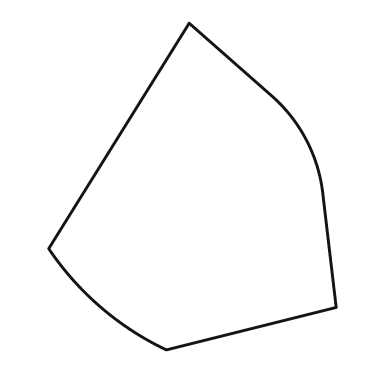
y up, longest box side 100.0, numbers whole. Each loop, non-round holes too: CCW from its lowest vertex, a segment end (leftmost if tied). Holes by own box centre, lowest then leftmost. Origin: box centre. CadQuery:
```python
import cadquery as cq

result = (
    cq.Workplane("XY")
    .moveTo(-8.0, -50.0)
    .lineTo(44.0, -37.0)
    .lineTo(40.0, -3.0)
    .threePointArc((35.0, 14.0), (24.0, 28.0))
    .lineTo(-1.0, 50.0)
    .lineTo(-44.0, -19.0)
    .threePointArc((-28.0, -37.0), (-8.0, -50.0))
    .close()
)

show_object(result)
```